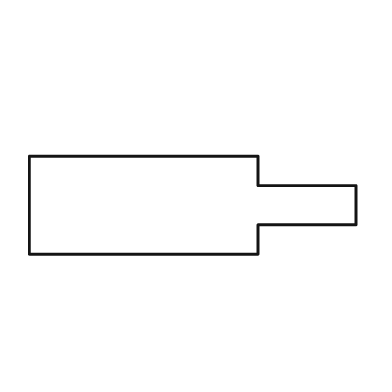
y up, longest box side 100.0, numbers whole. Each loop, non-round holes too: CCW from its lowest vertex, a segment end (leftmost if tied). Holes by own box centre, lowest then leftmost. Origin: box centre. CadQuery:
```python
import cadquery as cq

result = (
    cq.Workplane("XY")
    .moveTo(-50.0, -15.0)
    .lineTo(20.0, -15.0)
    .lineTo(20.0, -6.0)
    .lineTo(50.0, -6.0)
    .lineTo(50.0, 6.0)
    .lineTo(20.0, 6.0)
    .lineTo(20.0, 15.0)
    .lineTo(-50.0, 15.0)
    .close()
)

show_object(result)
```